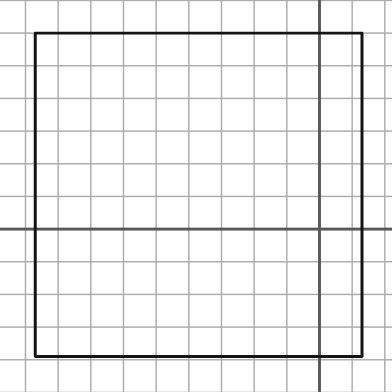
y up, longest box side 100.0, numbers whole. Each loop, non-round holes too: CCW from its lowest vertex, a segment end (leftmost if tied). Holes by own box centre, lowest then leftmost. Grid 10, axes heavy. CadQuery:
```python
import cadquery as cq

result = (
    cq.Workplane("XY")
    .moveTo(-87.0, -39.0)
    .lineTo(13.0, -39.0)
    .lineTo(13.0, 60.0)
    .lineTo(-87.0, 60.0)
    .close()
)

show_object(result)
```